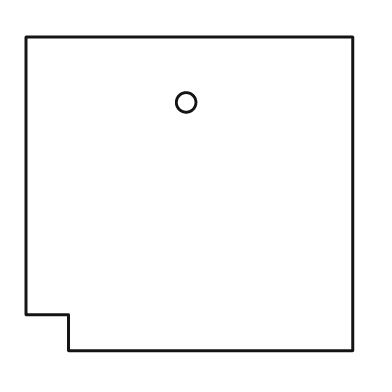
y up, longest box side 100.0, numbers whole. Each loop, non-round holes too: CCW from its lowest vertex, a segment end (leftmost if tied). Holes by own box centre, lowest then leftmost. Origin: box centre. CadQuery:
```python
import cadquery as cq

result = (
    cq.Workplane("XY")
    .moveTo(-37.0, -48.0)
    .lineTo(50.0, -48.0)
    .lineTo(50.0, 48.0)
    .lineTo(-50.0, 48.0)
    .lineTo(-50.0, -37.0)
    .lineTo(-37.0, -37.0)
    .close()
    .moveTo(-1.0, 28.0)
    .circle(3.0)
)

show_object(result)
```